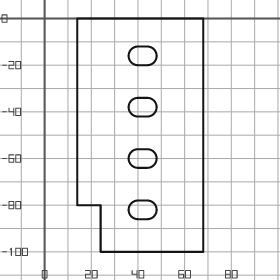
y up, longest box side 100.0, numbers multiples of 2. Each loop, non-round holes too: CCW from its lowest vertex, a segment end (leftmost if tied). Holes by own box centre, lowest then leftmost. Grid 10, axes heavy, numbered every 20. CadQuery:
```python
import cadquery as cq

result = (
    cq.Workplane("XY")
    .moveTo(24.0, -100.0)
    .lineTo(68.0, -100.0)
    .lineTo(68.0, 0.0)
    .lineTo(14.0, 0.0)
    .lineTo(14.0, -80.0)
    .lineTo(24.0, -80.0)
    .close()
    .moveTo(40.0, -86.0)
    .lineTo(44.0, -86.0)
    .threePointArc((48.0, -82.0), (44.0, -78.0))
    .lineTo(40.0, -78.0)
    .threePointArc((36.0, -82.0), (40.0, -86.0))
    .close()
    .moveTo(40.0, -64.0)
    .lineTo(44.0, -64.0)
    .threePointArc((48.0, -60.0), (44.0, -56.0))
    .lineTo(40.0, -56.0)
    .threePointArc((36.0, -60.0), (40.0, -64.0))
    .close()
    .moveTo(40.0, -42.0)
    .lineTo(44.0, -42.0)
    .threePointArc((48.0, -38.0), (44.0, -34.0))
    .lineTo(40.0, -34.0)
    .threePointArc((36.0, -38.0), (40.0, -42.0))
    .close()
    .moveTo(40.0, -20.0)
    .lineTo(44.0, -20.0)
    .threePointArc((48.0, -16.0), (44.0, -12.0))
    .lineTo(40.0, -12.0)
    .threePointArc((36.0, -16.0), (40.0, -20.0))
    .close()
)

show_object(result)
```